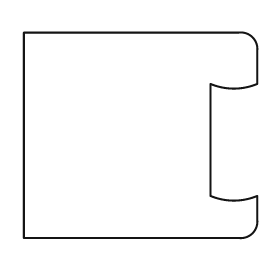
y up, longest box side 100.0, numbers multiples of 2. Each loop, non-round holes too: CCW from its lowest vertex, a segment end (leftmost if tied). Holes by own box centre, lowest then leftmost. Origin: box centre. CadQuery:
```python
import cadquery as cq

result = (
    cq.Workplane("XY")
    .moveTo(-50.0, -44.0)
    .lineTo(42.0, -44.0)
    .threePointArc((48.0, -42.0), (50.0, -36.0))
    .lineTo(50.0, -26.0)
    .threePointArc((40.0, -28.0), (30.0, -26.0))
    .lineTo(30.0, 22.0)
    .threePointArc((40.0, 20.0), (50.0, 22.0))
    .lineTo(50.0, 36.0)
    .threePointArc((48.0, 42.0), (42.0, 44.0))
    .lineTo(-50.0, 44.0)
    .close()
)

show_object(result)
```